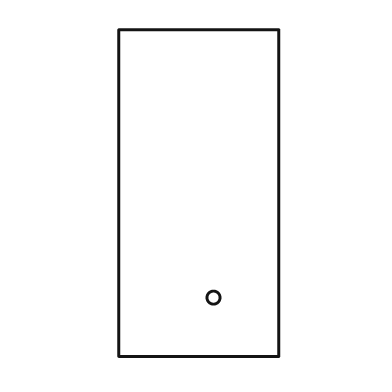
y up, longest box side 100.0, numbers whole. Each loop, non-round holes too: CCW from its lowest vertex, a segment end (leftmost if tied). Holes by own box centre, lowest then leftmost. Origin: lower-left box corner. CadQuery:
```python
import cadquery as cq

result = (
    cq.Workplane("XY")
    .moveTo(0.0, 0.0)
    .lineTo(49.0, 0.0)
    .lineTo(49.0, 100.0)
    .lineTo(0.0, 100.0)
    .close()
    .moveTo(29.0, 18.0)
    .circle(2.0)
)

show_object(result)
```